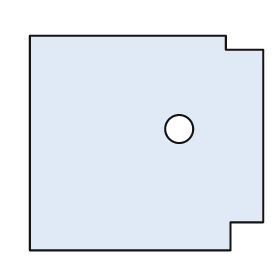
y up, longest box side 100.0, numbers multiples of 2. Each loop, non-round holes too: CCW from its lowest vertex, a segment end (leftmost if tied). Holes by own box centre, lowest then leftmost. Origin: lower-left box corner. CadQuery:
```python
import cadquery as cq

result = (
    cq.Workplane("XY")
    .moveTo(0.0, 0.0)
    .lineTo(86.0, 0.0)
    .lineTo(86.0, 12.0)
    .lineTo(100.0, 12.0)
    .lineTo(100.0, 86.0)
    .lineTo(84.0, 86.0)
    .lineTo(84.0, 92.0)
    .lineTo(0.0, 92.0)
    .close()
    .moveTo(64.0, 52.0)
    .circle(6.0)
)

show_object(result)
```